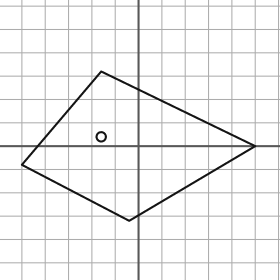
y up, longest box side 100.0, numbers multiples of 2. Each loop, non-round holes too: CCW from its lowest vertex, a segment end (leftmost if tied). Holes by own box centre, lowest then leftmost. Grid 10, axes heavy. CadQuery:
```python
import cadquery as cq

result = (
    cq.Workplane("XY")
    .moveTo(-4.0, -32.0)
    .lineTo(50.0, 0.0)
    .lineTo(-16.0, 32.0)
    .lineTo(-50.0, -8.0)
    .close()
    .moveTo(-16.0, 4.0)
    .circle(2.0)
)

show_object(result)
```